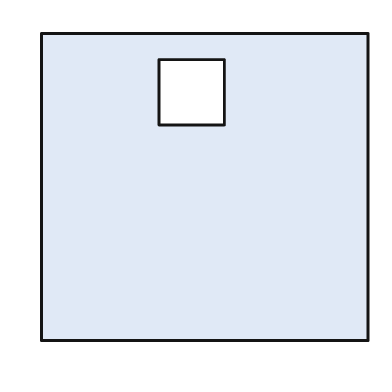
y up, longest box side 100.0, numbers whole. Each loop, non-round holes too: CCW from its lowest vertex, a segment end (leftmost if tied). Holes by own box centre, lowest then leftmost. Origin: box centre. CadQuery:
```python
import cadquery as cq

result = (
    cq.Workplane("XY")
    .moveTo(-50.0, -47.0)
    .lineTo(50.0, -47.0)
    .lineTo(50.0, 47.0)
    .lineTo(-50.0, 47.0)
    .close()
    .moveTo(-14.0, 19.0)
    .lineTo(6.0, 19.0)
    .lineTo(6.0, 39.0)
    .lineTo(-14.0, 39.0)
    .close()
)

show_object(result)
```